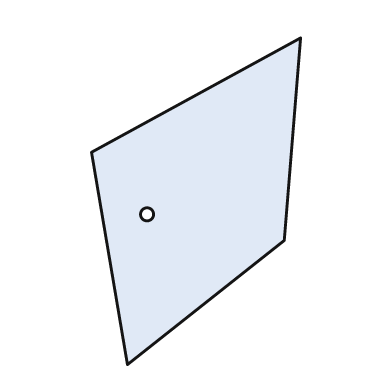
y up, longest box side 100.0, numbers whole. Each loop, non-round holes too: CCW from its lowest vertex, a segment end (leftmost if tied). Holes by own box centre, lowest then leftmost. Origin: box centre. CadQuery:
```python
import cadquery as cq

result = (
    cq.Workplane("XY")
    .moveTo(-21.0, -50.0)
    .lineTo(27.0, -12.0)
    .lineTo(32.0, 50.0)
    .lineTo(-32.0, 15.0)
    .close()
    .moveTo(-15.0, -4.0)
    .circle(2.0)
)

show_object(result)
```